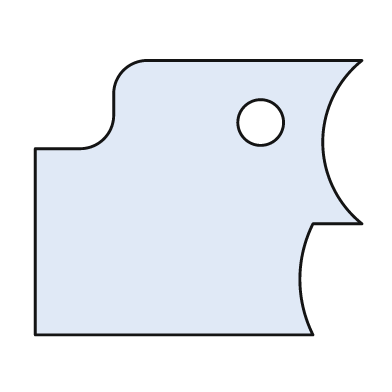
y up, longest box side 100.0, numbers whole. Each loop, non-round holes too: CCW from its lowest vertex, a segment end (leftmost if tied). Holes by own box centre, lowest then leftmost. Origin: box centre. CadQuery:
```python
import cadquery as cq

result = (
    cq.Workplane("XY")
    .moveTo(-50.0, -42.0)
    .lineTo(35.0, -42.0)
    .threePointArc((31.0, -25.0), (35.0, -8.0))
    .lineTo(50.0, -8.0)
    .threePointArc((38.0, 17.0), (50.0, 42.0))
    .lineTo(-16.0, 42.0)
    .threePointArc((-23.0, 39.0), (-26.0, 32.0))
    .lineTo(-26.0, 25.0)
    .threePointArc((-29.0, 18.0), (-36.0, 15.0))
    .lineTo(-50.0, 15.0)
    .close()
    .moveTo(19.0, 23.0)
    .circle(7.0)
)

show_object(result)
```